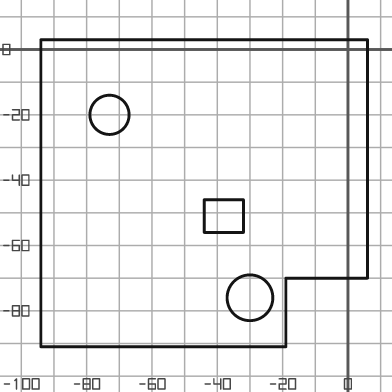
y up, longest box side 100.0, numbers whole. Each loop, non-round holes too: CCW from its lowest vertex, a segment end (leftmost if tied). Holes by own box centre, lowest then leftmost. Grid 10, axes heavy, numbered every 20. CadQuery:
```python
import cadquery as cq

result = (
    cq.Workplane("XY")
    .moveTo(-94.0, -91.0)
    .lineTo(-19.0, -91.0)
    .lineTo(-19.0, -70.0)
    .lineTo(6.0, -70.0)
    .lineTo(6.0, 3.0)
    .lineTo(-94.0, 3.0)
    .close()
    .moveTo(-30.0, -76.0)
    .circle(7.0)
    .moveTo(-44.0, -56.0)
    .lineTo(-32.0, -56.0)
    .lineTo(-32.0, -46.0)
    .lineTo(-44.0, -46.0)
    .close()
    .moveTo(-73.0, -20.0)
    .circle(6.0)
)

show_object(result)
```